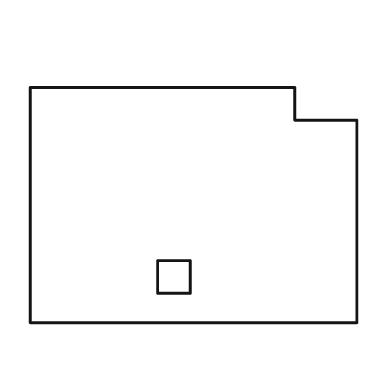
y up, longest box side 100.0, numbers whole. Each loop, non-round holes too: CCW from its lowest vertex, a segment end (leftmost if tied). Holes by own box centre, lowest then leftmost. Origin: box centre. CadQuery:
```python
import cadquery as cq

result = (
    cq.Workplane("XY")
    .moveTo(-50.0, -36.0)
    .lineTo(50.0, -36.0)
    .lineTo(50.0, 26.0)
    .lineTo(31.0, 26.0)
    .lineTo(31.0, 36.0)
    .lineTo(-50.0, 36.0)
    .close()
    .moveTo(-11.0, -27.0)
    .lineTo(-1.0, -27.0)
    .lineTo(-1.0, -17.0)
    .lineTo(-11.0, -17.0)
    .close()
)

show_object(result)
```